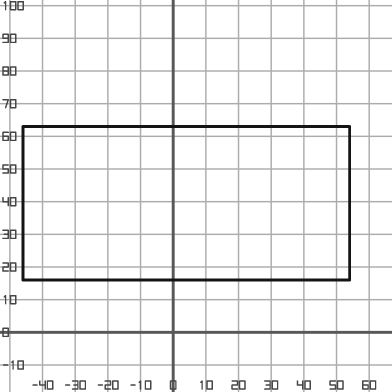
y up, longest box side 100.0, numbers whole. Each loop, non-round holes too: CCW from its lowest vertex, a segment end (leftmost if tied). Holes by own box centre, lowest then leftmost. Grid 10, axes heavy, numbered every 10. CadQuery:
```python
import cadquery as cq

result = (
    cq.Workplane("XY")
    .moveTo(-46.0, 16.0)
    .lineTo(54.0, 16.0)
    .lineTo(54.0, 63.0)
    .lineTo(-46.0, 63.0)
    .close()
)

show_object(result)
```